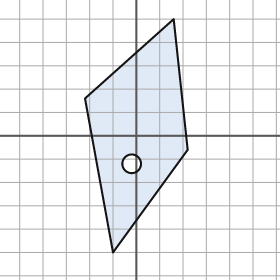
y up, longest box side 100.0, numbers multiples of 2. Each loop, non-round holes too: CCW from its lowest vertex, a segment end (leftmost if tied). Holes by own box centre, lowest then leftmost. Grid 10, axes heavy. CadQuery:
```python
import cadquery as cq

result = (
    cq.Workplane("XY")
    .moveTo(-10.0, -50.0)
    .lineTo(22.0, -6.0)
    .lineTo(16.0, 50.0)
    .lineTo(-22.0, 16.0)
    .close()
    .moveTo(-2.0, -12.0)
    .circle(4.0)
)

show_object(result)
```